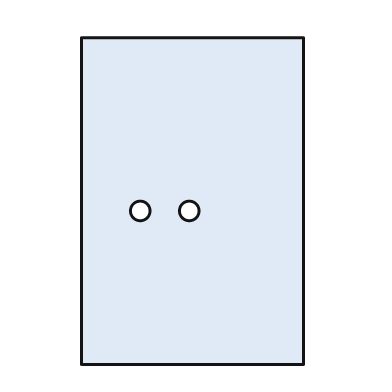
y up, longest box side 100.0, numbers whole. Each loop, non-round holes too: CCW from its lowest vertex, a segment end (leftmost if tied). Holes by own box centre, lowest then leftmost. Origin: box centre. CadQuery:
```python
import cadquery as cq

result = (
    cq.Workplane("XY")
    .moveTo(-34.0, -50.0)
    .lineTo(34.0, -50.0)
    .lineTo(34.0, 50.0)
    .lineTo(-34.0, 50.0)
    .close()
    .moveTo(-16.0, -3.0)
    .circle(3.0)
    .moveTo(-1.0, -3.0)
    .circle(3.0)
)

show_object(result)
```